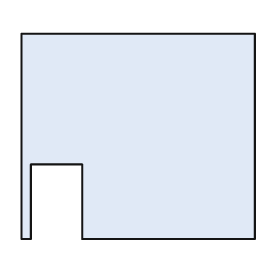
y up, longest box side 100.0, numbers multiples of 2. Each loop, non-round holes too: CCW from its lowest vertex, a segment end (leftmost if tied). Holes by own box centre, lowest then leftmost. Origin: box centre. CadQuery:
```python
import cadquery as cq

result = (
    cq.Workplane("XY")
    .moveTo(-50.0, -44.0)
    .lineTo(-46.0, -44.0)
    .lineTo(-46.0, -12.0)
    .lineTo(-24.0, -12.0)
    .lineTo(-24.0, -44.0)
    .lineTo(50.0, -44.0)
    .lineTo(50.0, 44.0)
    .lineTo(-50.0, 44.0)
    .close()
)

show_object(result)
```